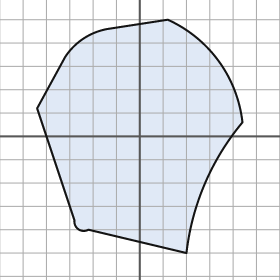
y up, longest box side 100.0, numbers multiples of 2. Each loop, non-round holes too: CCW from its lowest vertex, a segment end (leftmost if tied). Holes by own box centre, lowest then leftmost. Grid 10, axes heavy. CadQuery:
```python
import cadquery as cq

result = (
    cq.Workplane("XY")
    .moveTo(20.0, -50.0)
    .threePointArc((28.0, -20.0), (44.0, 6.0))
    .threePointArc((34.0, 32.0), (12.0, 50.0))
    .lineTo(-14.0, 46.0)
    .threePointArc((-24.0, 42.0), (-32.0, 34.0))
    .lineTo(-44.0, 12.0)
    .lineTo(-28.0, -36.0)
    .threePointArc((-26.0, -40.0), (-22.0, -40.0))
    .close()
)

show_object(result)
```